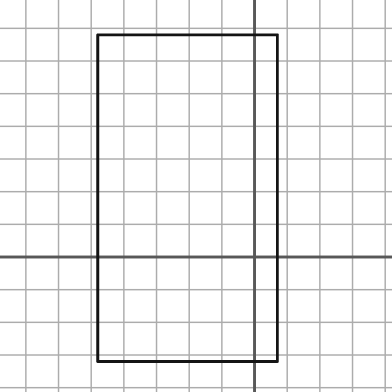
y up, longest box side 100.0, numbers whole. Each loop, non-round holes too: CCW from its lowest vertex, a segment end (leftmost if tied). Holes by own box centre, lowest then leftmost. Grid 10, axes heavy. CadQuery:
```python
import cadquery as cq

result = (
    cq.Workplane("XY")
    .moveTo(-48.0, -32.0)
    .lineTo(7.0, -32.0)
    .lineTo(7.0, 68.0)
    .lineTo(-48.0, 68.0)
    .close()
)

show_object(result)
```